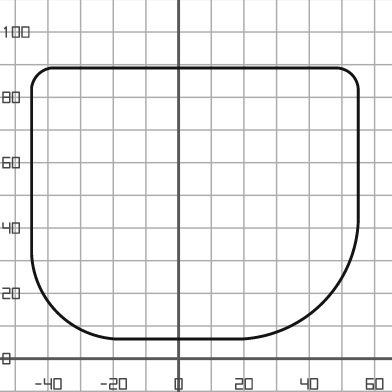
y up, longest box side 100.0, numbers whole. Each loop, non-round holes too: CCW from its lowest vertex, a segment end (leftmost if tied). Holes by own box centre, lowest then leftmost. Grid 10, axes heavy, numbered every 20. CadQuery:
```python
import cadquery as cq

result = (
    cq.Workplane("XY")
    .moveTo(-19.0, 6.0)
    .lineTo(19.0, 6.0)
    .threePointArc((44.0, 17.0), (55.0, 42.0))
    .lineTo(55.0, 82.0)
    .threePointArc((53.0, 87.0), (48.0, 89.0))
    .lineTo(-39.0, 89.0)
    .threePointArc((-43.0, 87.0), (-45.0, 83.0))
    .lineTo(-45.0, 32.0)
    .threePointArc((-37.0, 14.0), (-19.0, 6.0))
    .close()
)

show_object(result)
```